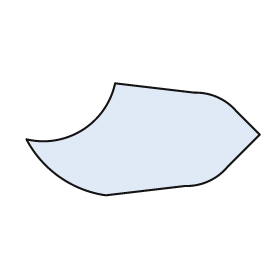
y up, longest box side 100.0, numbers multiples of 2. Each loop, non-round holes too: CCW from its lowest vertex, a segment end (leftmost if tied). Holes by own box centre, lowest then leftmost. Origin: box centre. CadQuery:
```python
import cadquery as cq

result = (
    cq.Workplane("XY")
    .moveTo(-16.0, -24.0)
    .lineTo(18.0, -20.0)
    .threePointArc((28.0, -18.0), (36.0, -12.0))
    .lineTo(50.0, 2.0)
    .lineTo(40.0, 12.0)
    .threePointArc((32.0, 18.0), (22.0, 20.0))
    .lineTo(-12.0, 24.0)
    .threePointArc((-26.0, 4.0), (-50.0, 0.0))
    .threePointArc((-36.0, -16.0), (-16.0, -24.0))
    .close()
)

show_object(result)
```